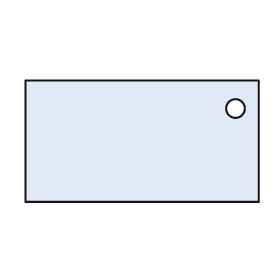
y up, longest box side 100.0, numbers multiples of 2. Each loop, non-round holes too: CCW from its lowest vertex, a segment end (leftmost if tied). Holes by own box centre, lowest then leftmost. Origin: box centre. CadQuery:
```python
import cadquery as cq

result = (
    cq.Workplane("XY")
    .moveTo(-50.0, -26.0)
    .lineTo(50.0, -26.0)
    .lineTo(50.0, 26.0)
    .lineTo(-50.0, 26.0)
    .close()
    .moveTo(40.0, 14.0)
    .circle(4.0)
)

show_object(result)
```